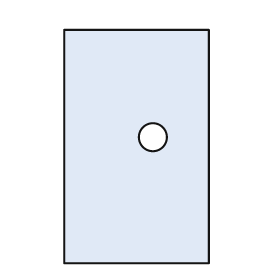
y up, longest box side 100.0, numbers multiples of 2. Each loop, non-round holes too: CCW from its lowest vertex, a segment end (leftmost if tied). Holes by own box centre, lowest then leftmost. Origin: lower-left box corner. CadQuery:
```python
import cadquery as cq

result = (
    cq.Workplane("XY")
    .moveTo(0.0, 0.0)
    .lineTo(62.0, 0.0)
    .lineTo(62.0, 100.0)
    .lineTo(0.0, 100.0)
    .close()
    .moveTo(38.0, 54.0)
    .circle(6.0)
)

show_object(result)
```